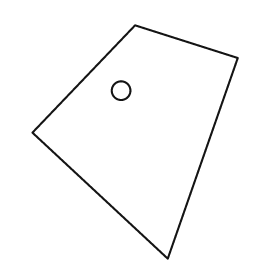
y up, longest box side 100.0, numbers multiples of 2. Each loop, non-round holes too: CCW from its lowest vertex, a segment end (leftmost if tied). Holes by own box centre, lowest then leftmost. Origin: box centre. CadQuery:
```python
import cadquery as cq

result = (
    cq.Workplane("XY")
    .moveTo(14.0, -50.0)
    .lineTo(44.0, 36.0)
    .lineTo(0.0, 50.0)
    .lineTo(-44.0, 4.0)
    .close()
    .moveTo(-6.0, 22.0)
    .circle(4.0)
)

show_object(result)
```